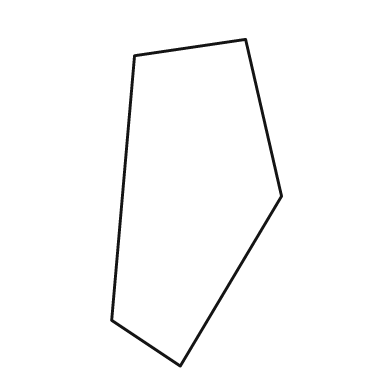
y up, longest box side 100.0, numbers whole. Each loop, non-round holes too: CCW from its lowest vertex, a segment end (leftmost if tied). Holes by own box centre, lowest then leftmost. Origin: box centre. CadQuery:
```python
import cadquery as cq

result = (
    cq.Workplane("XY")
    .moveTo(-5.0, -50.0)
    .lineTo(26.0, 2.0)
    .lineTo(15.0, 50.0)
    .lineTo(-19.0, 45.0)
    .lineTo(-26.0, -36.0)
    .close()
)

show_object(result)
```